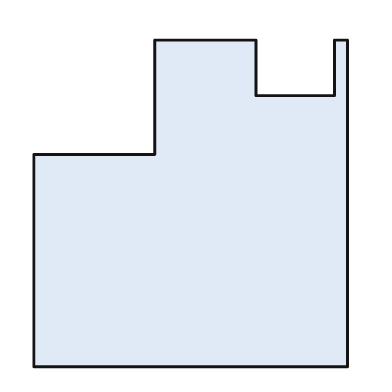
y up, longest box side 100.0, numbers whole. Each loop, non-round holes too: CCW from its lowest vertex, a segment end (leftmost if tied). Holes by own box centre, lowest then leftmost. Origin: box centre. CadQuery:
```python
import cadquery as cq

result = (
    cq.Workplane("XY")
    .moveTo(-48.0, -50.0)
    .lineTo(48.0, -50.0)
    .lineTo(48.0, 50.0)
    .lineTo(44.0, 50.0)
    .lineTo(44.0, 33.0)
    .lineTo(20.0, 33.0)
    .lineTo(20.0, 50.0)
    .lineTo(-11.0, 50.0)
    .lineTo(-11.0, 15.0)
    .lineTo(-48.0, 15.0)
    .close()
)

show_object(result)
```